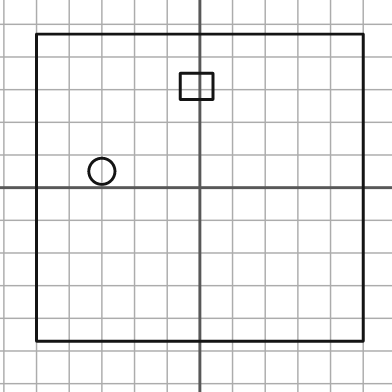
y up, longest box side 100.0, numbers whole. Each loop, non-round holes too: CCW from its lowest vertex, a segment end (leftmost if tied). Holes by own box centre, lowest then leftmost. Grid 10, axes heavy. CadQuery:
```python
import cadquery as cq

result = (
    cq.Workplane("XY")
    .moveTo(-50.0, -47.0)
    .lineTo(50.0, -47.0)
    .lineTo(50.0, 47.0)
    .lineTo(-50.0, 47.0)
    .close()
    .moveTo(-30.0, 5.0)
    .circle(4.0)
    .moveTo(-6.0, 27.0)
    .lineTo(4.0, 27.0)
    .lineTo(4.0, 35.0)
    .lineTo(-6.0, 35.0)
    .close()
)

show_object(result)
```